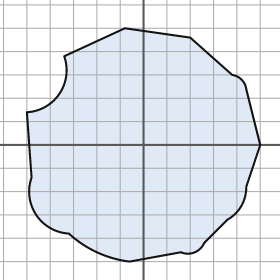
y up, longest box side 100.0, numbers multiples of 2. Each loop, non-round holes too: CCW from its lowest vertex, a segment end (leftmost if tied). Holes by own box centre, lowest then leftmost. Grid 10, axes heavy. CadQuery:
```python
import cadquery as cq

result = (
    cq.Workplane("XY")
    .moveTo(-6.0, -50.0)
    .lineTo(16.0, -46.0)
    .threePointArc((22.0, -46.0), (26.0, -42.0))
    .lineTo(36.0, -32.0)
    .threePointArc((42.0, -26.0), (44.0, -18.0))
    .lineTo(50.0, 0.0)
    .lineTo(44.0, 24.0)
    .threePointArc((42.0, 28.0), (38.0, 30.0))
    .lineTo(20.0, 46.0)
    .lineTo(-8.0, 50.0)
    .lineTo(-34.0, 38.0)
    .threePointArc((-36.0, 22.0), (-50.0, 14.0))
    .lineTo(-48.0, -14.0)
    .threePointArc((-46.0, -30.0), (-32.0, -38.0))
    .threePointArc((-20.0, -46.0), (-6.0, -50.0))
    .close()
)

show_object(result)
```